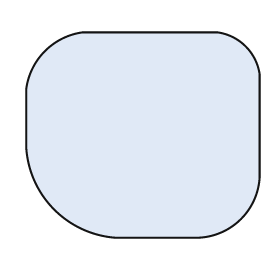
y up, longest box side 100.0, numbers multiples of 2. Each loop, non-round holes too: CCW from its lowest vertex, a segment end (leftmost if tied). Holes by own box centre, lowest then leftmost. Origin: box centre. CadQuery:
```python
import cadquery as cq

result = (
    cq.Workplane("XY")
    .moveTo(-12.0, -44.0)
    .lineTo(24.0, -44.0)
    .threePointArc((42.0, -36.0), (50.0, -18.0))
    .lineTo(50.0, 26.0)
    .threePointArc((44.0, 38.0), (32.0, 44.0))
    .lineTo(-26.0, 44.0)
    .threePointArc((-42.0, 36.0), (-50.0, 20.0))
    .lineTo(-50.0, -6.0)
    .threePointArc((-38.0, -32.0), (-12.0, -44.0))
    .close()
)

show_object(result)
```